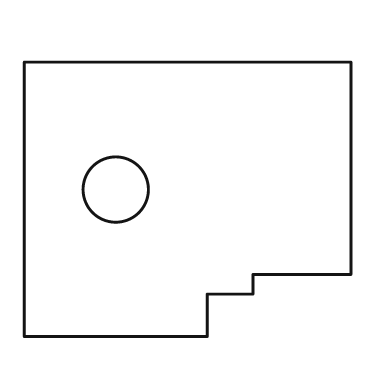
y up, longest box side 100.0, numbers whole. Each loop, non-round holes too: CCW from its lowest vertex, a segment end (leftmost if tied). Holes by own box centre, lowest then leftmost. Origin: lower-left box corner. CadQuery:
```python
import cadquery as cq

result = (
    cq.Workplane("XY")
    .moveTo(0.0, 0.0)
    .lineTo(56.0, 0.0)
    .lineTo(56.0, 13.0)
    .lineTo(70.0, 13.0)
    .lineTo(70.0, 19.0)
    .lineTo(100.0, 19.0)
    .lineTo(100.0, 84.0)
    .lineTo(0.0, 84.0)
    .close()
    .moveTo(28.0, 45.0)
    .circle(10.0)
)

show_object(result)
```